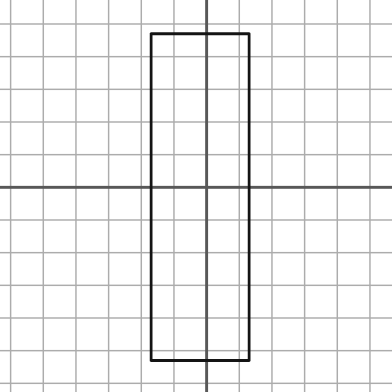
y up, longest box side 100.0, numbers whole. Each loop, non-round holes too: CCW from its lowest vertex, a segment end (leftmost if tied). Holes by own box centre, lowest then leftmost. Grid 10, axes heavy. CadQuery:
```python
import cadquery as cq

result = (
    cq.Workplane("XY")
    .moveTo(-17.0, -53.0)
    .lineTo(13.0, -53.0)
    .lineTo(13.0, 47.0)
    .lineTo(-17.0, 47.0)
    .close()
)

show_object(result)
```